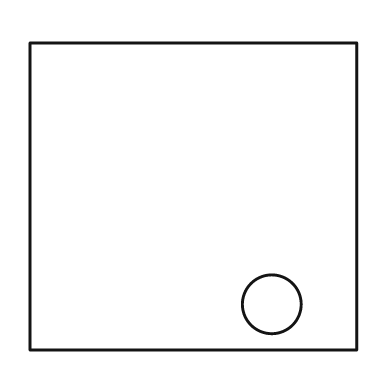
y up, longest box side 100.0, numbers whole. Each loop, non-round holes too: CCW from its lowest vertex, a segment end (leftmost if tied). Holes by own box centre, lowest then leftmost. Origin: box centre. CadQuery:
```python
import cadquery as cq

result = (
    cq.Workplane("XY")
    .moveTo(-50.0, -47.0)
    .lineTo(50.0, -47.0)
    .lineTo(50.0, 47.0)
    .lineTo(-50.0, 47.0)
    .close()
    .moveTo(24.0, -33.0)
    .circle(9.0)
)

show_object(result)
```